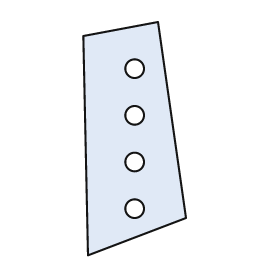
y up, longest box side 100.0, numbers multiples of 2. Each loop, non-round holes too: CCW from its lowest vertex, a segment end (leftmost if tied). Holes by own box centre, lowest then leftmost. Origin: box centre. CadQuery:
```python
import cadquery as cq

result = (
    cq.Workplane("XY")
    .moveTo(-20.0, -50.0)
    .lineTo(22.0, -34.0)
    .lineTo(10.0, 50.0)
    .lineTo(-22.0, 44.0)
    .close()
    .moveTo(0.0, -30.0)
    .circle(4.0)
    .moveTo(0.0, -10.0)
    .circle(4.0)
    .moveTo(0.0, 10.0)
    .circle(4.0)
    .moveTo(0.0, 30.0)
    .circle(4.0)
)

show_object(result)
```